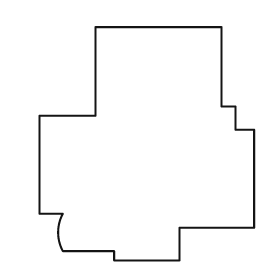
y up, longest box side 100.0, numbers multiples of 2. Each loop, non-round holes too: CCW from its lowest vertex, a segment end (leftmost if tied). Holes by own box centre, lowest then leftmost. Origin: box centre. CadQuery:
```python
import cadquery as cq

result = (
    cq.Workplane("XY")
    .moveTo(-14.0, -50.0)
    .lineTo(14.0, -50.0)
    .lineTo(14.0, -36.0)
    .lineTo(46.0, -36.0)
    .lineTo(46.0, 6.0)
    .lineTo(38.0, 6.0)
    .lineTo(38.0, 16.0)
    .lineTo(32.0, 16.0)
    .lineTo(32.0, 50.0)
    .lineTo(-22.0, 50.0)
    .lineTo(-22.0, 12.0)
    .lineTo(-46.0, 12.0)
    .lineTo(-46.0, -30.0)
    .lineTo(-36.0, -30.0)
    .threePointArc((-38.0, -38.0), (-36.0, -46.0))
    .lineTo(-14.0, -46.0)
    .close()
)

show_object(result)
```